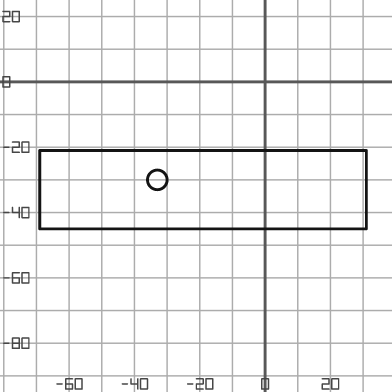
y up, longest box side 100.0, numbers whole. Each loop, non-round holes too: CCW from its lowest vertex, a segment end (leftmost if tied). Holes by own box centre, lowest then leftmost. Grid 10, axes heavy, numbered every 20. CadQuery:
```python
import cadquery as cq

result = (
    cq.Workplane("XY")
    .moveTo(-69.0, -45.0)
    .lineTo(31.0, -45.0)
    .lineTo(31.0, -21.0)
    .lineTo(-69.0, -21.0)
    .close()
    .moveTo(-33.0, -30.0)
    .circle(3.0)
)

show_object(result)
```